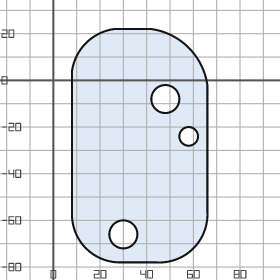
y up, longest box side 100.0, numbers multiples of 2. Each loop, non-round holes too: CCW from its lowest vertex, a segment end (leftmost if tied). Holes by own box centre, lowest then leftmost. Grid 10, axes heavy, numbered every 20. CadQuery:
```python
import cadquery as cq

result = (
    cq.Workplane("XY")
    .moveTo(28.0, -78.0)
    .lineTo(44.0, -78.0)
    .threePointArc((60.0, -72.0), (66.0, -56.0))
    .lineTo(66.0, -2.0)
    .threePointArc((58.0, 14.0), (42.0, 22.0))
    .lineTo(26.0, 22.0)
    .threePointArc((14.0, 16.0), (8.0, 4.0))
    .lineTo(8.0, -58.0)
    .threePointArc((14.0, -72.0), (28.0, -78.0))
    .close()
    .moveTo(30.0, -66.0)
    .circle(6.0)
    .moveTo(58.0, -24.0)
    .circle(4.0)
    .moveTo(48.0, -8.0)
    .circle(6.0)
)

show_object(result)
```